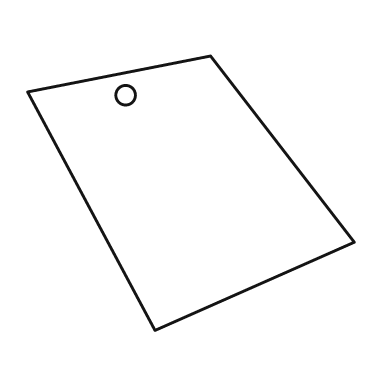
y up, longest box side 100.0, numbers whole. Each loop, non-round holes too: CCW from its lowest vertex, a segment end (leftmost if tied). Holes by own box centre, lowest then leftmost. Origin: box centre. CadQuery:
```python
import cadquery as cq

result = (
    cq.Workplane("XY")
    .moveTo(-11.0, -42.0)
    .lineTo(50.0, -15.0)
    .lineTo(6.0, 42.0)
    .lineTo(-50.0, 31.0)
    .close()
    .moveTo(-20.0, 30.0)
    .circle(3.0)
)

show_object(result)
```